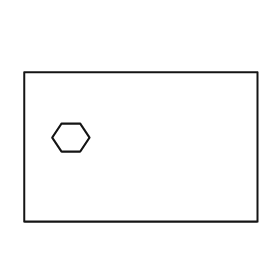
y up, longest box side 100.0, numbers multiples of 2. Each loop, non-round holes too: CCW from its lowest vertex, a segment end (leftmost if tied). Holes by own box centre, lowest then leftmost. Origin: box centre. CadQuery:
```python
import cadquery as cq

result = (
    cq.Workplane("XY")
    .moveTo(-50.0, -32.0)
    .lineTo(50.0, -32.0)
    .lineTo(50.0, 32.0)
    .lineTo(-50.0, 32.0)
    .close()
    .moveTo(-34.0, -2.0)
    .lineTo(-26.0, -2.0)
    .lineTo(-22.0, 4.0)
    .lineTo(-26.0, 10.0)
    .lineTo(-34.0, 10.0)
    .lineTo(-38.0, 4.0)
    .close()
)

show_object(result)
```